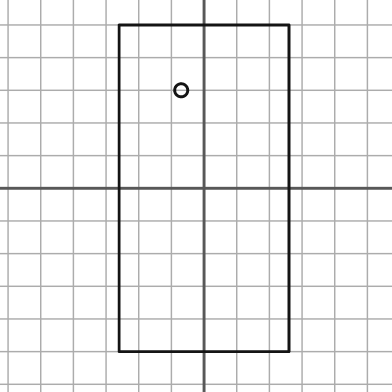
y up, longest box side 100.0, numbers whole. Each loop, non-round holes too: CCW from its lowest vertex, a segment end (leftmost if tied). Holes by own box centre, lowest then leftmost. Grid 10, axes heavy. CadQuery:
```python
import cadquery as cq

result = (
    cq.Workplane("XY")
    .moveTo(-26.0, -50.0)
    .lineTo(26.0, -50.0)
    .lineTo(26.0, 50.0)
    .lineTo(-26.0, 50.0)
    .close()
    .moveTo(-7.0, 30.0)
    .circle(2.0)
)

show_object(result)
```